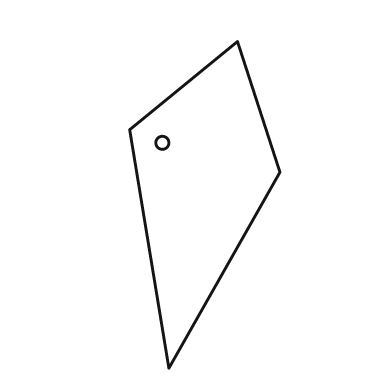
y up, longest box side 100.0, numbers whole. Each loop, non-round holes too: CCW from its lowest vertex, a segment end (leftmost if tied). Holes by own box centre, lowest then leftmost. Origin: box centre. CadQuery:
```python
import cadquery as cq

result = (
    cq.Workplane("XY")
    .moveTo(-11.0, -50.0)
    .lineTo(23.0, 10.0)
    .lineTo(10.0, 50.0)
    .lineTo(-23.0, 23.0)
    .close()
    .moveTo(-13.0, 19.0)
    .circle(2.0)
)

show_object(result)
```